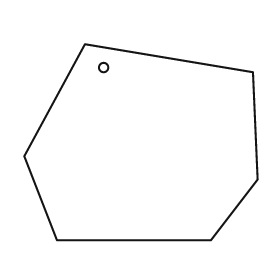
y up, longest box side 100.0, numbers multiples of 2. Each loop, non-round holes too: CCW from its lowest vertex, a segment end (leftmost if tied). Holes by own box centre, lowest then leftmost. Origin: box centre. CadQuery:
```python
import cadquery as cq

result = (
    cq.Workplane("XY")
    .moveTo(-36.0, -42.0)
    .lineTo(30.0, -42.0)
    .lineTo(50.0, -16.0)
    .lineTo(48.0, 30.0)
    .lineTo(-24.0, 42.0)
    .lineTo(-50.0, -6.0)
    .close()
    .moveTo(-16.0, 32.0)
    .circle(2.0)
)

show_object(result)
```